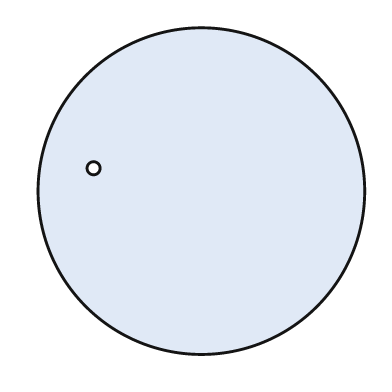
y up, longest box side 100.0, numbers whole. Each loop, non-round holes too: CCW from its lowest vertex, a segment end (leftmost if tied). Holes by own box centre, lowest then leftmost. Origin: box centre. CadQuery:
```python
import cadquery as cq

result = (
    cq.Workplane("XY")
    .moveTo(0.0, 0.0)
    .circle(50.0)
    .moveTo(-33.0, 7.0)
    .circle(2.0)
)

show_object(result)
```